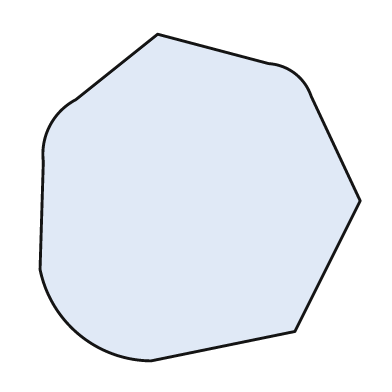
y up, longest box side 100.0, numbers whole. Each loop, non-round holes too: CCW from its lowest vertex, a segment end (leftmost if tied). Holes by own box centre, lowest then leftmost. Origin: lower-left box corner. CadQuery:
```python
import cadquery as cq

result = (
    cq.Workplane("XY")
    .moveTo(34.0, 0.0)
    .lineTo(78.0, 9.0)
    .lineTo(98.0, 49.0)
    .lineTo(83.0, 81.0)
    .threePointArc((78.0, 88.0), (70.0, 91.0))
    .lineTo(36.0, 100.0)
    .lineTo(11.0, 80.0)
    .threePointArc((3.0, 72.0), (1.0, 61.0))
    .lineTo(0.0, 28.0)
    .threePointArc((12.0, 8.0), (34.0, 0.0))
    .close()
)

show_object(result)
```